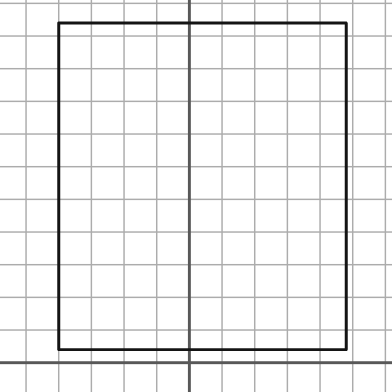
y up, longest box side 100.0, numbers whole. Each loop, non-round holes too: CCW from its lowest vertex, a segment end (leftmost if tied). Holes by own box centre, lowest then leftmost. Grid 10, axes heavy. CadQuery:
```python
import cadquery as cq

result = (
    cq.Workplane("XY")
    .moveTo(-40.0, 4.0)
    .lineTo(48.0, 4.0)
    .lineTo(48.0, 104.0)
    .lineTo(-40.0, 104.0)
    .close()
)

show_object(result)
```